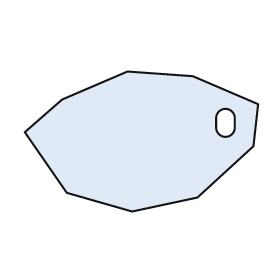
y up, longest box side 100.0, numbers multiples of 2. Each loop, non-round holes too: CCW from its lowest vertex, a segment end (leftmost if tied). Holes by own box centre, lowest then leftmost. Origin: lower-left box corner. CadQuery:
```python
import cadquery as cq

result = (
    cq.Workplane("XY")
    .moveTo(46.0, 0.0)
    .lineTo(74.0, 6.0)
    .lineTo(98.0, 28.0)
    .lineTo(100.0, 46.0)
    .lineTo(72.0, 58.0)
    .lineTo(44.0, 60.0)
    .lineTo(16.0, 48.0)
    .lineTo(0.0, 34.0)
    .lineTo(18.0, 8.0)
    .close()
    .moveTo(82.0, 36.0)
    .threePointArc((86.0, 32.0), (90.0, 36.0))
    .lineTo(90.0, 40.0)
    .threePointArc((86.0, 44.0), (82.0, 40.0))
    .close()
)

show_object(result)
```